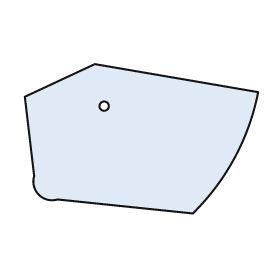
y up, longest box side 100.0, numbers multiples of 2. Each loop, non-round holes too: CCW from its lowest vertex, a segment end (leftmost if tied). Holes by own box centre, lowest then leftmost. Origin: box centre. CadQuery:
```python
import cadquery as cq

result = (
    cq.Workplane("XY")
    .moveTo(22.0, -32.0)
    .threePointArc((40.0, -8.0), (50.0, 20.0))
    .lineTo(-20.0, 32.0)
    .lineTo(-50.0, 18.0)
    .lineTo(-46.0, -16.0)
    .threePointArc((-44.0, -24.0), (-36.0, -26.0))
    .close()
    .moveTo(-16.0, 14.0)
    .circle(2.0)
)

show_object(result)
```